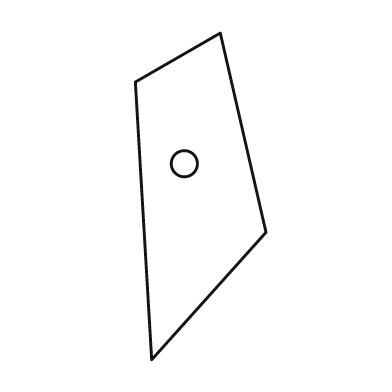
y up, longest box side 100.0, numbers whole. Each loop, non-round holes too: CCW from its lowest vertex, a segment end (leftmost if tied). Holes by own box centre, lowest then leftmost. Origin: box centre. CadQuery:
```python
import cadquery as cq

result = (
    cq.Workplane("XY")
    .moveTo(-15.0, -50.0)
    .lineTo(20.0, -11.0)
    .lineTo(6.0, 50.0)
    .lineTo(-20.0, 35.0)
    .close()
    .moveTo(-5.0, 10.0)
    .circle(4.0)
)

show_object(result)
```